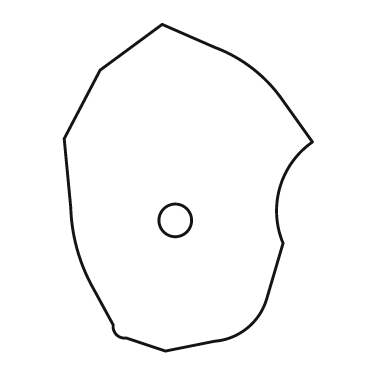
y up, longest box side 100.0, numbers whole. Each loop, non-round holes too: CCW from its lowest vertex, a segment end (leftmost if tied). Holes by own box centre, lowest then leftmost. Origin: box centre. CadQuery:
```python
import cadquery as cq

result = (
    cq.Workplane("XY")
    .moveTo(-7.0, -50.0)
    .lineTo(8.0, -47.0)
    .threePointArc((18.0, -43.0), (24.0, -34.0))
    .lineTo(29.0, -17.0)
    .threePointArc((28.0, 0.0), (38.0, 14.0))
    .lineTo(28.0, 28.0)
    .threePointArc((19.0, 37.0), (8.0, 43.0))
    .lineTo(-8.0, 50.0)
    .lineTo(-27.0, 36.0)
    .lineTo(-38.0, 15.0)
    .lineTo(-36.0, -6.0)
    .threePointArc((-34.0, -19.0), (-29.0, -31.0))
    .lineTo(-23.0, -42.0)
    .threePointArc((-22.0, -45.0), (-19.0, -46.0))
    .close()
    .moveTo(-4.0, -10.0)
    .circle(5.0)
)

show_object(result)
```